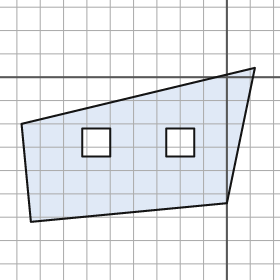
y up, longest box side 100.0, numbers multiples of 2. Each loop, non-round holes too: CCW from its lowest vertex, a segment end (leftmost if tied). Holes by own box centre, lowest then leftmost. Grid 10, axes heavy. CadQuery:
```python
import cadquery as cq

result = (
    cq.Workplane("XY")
    .moveTo(-84.0, -62.0)
    .lineTo(0.0, -54.0)
    .lineTo(12.0, 4.0)
    .lineTo(-88.0, -20.0)
    .close()
    .moveTo(-62.0, -34.0)
    .lineTo(-50.0, -34.0)
    .lineTo(-50.0, -22.0)
    .lineTo(-62.0, -22.0)
    .close()
    .moveTo(-26.0, -34.0)
    .lineTo(-14.0, -34.0)
    .lineTo(-14.0, -22.0)
    .lineTo(-26.0, -22.0)
    .close()
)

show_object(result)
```